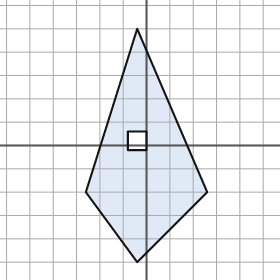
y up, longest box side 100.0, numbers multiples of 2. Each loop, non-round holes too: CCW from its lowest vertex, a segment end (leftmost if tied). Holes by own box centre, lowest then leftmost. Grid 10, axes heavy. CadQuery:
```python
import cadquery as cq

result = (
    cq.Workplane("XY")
    .moveTo(-4.0, -50.0)
    .lineTo(26.0, -20.0)
    .lineTo(-4.0, 50.0)
    .lineTo(-26.0, -20.0)
    .close()
    .moveTo(-8.0, -2.0)
    .lineTo(0.0, -2.0)
    .lineTo(0.0, 6.0)
    .lineTo(-8.0, 6.0)
    .close()
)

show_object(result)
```